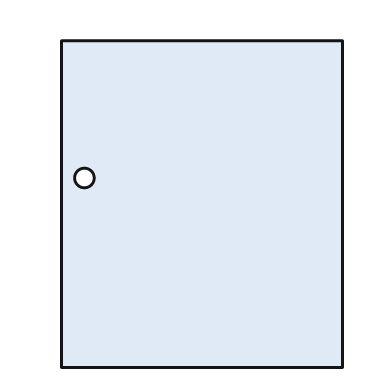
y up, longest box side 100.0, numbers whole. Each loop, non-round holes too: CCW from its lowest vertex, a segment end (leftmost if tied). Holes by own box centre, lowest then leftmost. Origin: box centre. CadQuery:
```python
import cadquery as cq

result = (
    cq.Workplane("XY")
    .moveTo(-43.0, -50.0)
    .lineTo(43.0, -50.0)
    .lineTo(43.0, 50.0)
    .lineTo(-43.0, 50.0)
    .close()
    .moveTo(-36.0, 8.0)
    .circle(3.0)
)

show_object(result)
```